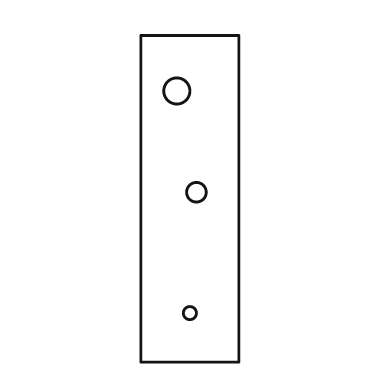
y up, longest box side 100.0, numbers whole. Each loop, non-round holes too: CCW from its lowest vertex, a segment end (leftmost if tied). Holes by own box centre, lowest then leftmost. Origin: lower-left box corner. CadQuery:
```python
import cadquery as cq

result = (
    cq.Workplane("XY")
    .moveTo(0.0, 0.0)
    .lineTo(30.0, 0.0)
    .lineTo(30.0, 100.0)
    .lineTo(0.0, 100.0)
    .close()
    .moveTo(15.0, 15.0)
    .circle(2.0)
    .moveTo(17.0, 52.0)
    .circle(3.0)
    .moveTo(11.0, 83.0)
    .circle(4.0)
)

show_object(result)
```